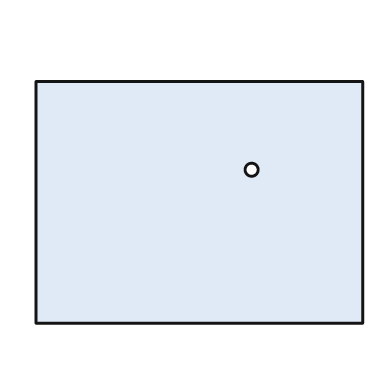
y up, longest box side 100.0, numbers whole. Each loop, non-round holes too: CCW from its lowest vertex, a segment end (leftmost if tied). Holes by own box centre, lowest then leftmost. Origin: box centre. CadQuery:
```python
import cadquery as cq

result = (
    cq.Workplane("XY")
    .moveTo(-50.0, -37.0)
    .lineTo(50.0, -37.0)
    .lineTo(50.0, 37.0)
    .lineTo(-50.0, 37.0)
    .close()
    .moveTo(16.0, 10.0)
    .circle(2.0)
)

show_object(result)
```